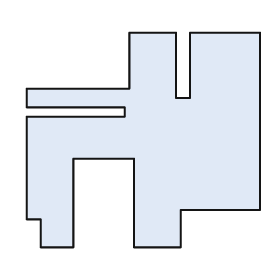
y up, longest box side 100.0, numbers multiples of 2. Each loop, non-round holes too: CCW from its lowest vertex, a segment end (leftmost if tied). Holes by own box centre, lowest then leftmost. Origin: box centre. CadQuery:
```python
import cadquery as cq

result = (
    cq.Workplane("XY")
    .moveTo(-44.0, -46.0)
    .lineTo(-30.0, -46.0)
    .lineTo(-30.0, -8.0)
    .lineTo(-4.0, -8.0)
    .lineTo(-4.0, -46.0)
    .lineTo(16.0, -46.0)
    .lineTo(16.0, -30.0)
    .lineTo(50.0, -30.0)
    .lineTo(50.0, 46.0)
    .lineTo(20.0, 46.0)
    .lineTo(20.0, 18.0)
    .lineTo(14.0, 18.0)
    .lineTo(14.0, 46.0)
    .lineTo(-6.0, 46.0)
    .lineTo(-6.0, 22.0)
    .lineTo(-50.0, 22.0)
    .lineTo(-50.0, 14.0)
    .lineTo(-8.0, 14.0)
    .lineTo(-8.0, 10.0)
    .lineTo(-50.0, 10.0)
    .lineTo(-50.0, -34.0)
    .lineTo(-44.0, -34.0)
    .close()
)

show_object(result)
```